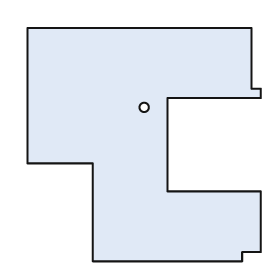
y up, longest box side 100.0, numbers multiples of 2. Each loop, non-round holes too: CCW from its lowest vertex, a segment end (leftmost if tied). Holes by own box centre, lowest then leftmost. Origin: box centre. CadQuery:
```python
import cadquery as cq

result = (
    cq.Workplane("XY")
    .moveTo(-22.0, -50.0)
    .lineTo(42.0, -50.0)
    .lineTo(42.0, -46.0)
    .lineTo(50.0, -46.0)
    .lineTo(50.0, -20.0)
    .lineTo(10.0, -20.0)
    .lineTo(10.0, 20.0)
    .lineTo(50.0, 20.0)
    .lineTo(50.0, 24.0)
    .lineTo(46.0, 24.0)
    .lineTo(46.0, 50.0)
    .lineTo(-50.0, 50.0)
    .lineTo(-50.0, -8.0)
    .lineTo(-22.0, -8.0)
    .close()
    .moveTo(0.0, 16.0)
    .circle(2.0)
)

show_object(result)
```